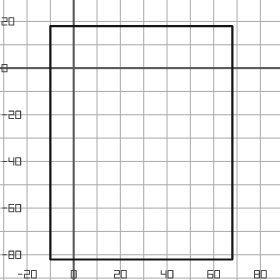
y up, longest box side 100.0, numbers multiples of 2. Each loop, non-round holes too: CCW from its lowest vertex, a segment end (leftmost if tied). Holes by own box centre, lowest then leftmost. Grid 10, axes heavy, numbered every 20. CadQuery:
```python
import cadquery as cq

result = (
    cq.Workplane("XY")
    .moveTo(-10.0, -82.0)
    .lineTo(68.0, -82.0)
    .lineTo(68.0, 18.0)
    .lineTo(-10.0, 18.0)
    .close()
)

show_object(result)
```